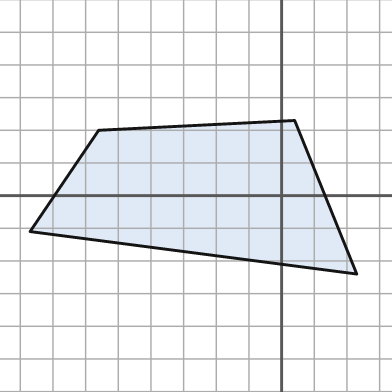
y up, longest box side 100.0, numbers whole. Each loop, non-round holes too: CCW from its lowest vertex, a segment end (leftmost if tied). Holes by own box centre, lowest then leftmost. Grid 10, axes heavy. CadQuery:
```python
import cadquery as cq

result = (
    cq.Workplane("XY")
    .moveTo(23.0, -24.0)
    .lineTo(4.0, 23.0)
    .lineTo(-56.0, 20.0)
    .lineTo(-77.0, -11.0)
    .close()
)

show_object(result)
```